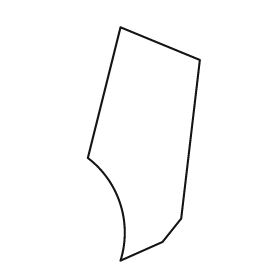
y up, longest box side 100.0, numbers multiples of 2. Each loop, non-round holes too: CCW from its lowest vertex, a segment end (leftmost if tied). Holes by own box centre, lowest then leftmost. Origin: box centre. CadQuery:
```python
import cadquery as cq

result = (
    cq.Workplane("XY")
    .moveTo(-10.0, -50.0)
    .lineTo(8.0, -42.0)
    .lineTo(16.0, -32.0)
    .lineTo(24.0, 36.0)
    .lineTo(-10.0, 50.0)
    .lineTo(-24.0, -6.0)
    .threePointArc((-10.0, -26.0), (-10.0, -50.0))
    .close()
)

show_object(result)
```